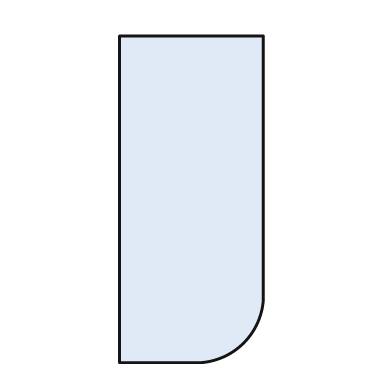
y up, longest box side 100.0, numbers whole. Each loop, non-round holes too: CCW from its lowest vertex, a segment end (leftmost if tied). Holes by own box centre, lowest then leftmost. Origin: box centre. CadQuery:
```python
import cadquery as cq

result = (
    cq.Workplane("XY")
    .moveTo(-22.0, -50.0)
    .lineTo(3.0, -50.0)
    .threePointArc((16.0, -44.0), (22.0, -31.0))
    .lineTo(22.0, 50.0)
    .lineTo(-22.0, 50.0)
    .close()
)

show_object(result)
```